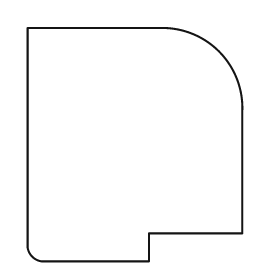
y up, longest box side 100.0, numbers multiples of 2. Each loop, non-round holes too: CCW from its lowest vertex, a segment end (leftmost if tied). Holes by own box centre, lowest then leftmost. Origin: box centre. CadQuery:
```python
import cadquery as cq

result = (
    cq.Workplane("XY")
    .moveTo(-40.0, -50.0)
    .lineTo(6.0, -50.0)
    .lineTo(6.0, -38.0)
    .lineTo(46.0, -38.0)
    .lineTo(46.0, 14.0)
    .threePointArc((36.0, 40.0), (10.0, 50.0))
    .lineTo(-46.0, 50.0)
    .lineTo(-46.0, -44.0)
    .threePointArc((-44.0, -48.0), (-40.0, -50.0))
    .close()
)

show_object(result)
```